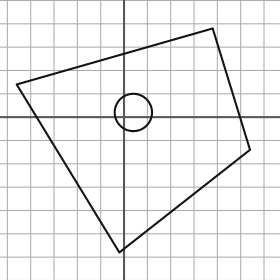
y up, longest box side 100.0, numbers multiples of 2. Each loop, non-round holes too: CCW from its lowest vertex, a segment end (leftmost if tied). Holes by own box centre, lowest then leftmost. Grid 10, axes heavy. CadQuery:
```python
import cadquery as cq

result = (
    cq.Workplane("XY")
    .moveTo(-2.0, -58.0)
    .lineTo(54.0, -14.0)
    .lineTo(38.0, 38.0)
    .lineTo(-46.0, 14.0)
    .close()
    .moveTo(4.0, 2.0)
    .circle(8.0)
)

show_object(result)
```